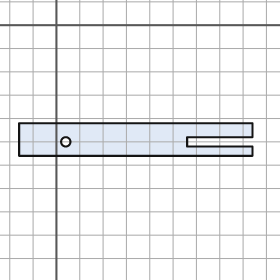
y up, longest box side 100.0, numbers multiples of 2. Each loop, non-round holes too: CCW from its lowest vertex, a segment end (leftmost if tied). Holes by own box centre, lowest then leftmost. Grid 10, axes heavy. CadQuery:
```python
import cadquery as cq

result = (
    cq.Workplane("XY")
    .moveTo(-16.0, -56.0)
    .lineTo(84.0, -56.0)
    .lineTo(84.0, -52.0)
    .lineTo(56.0, -52.0)
    .lineTo(56.0, -48.0)
    .lineTo(84.0, -48.0)
    .lineTo(84.0, -42.0)
    .lineTo(-16.0, -42.0)
    .close()
    .moveTo(4.0, -50.0)
    .circle(2.0)
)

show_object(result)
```